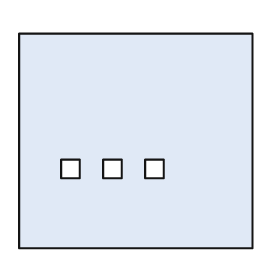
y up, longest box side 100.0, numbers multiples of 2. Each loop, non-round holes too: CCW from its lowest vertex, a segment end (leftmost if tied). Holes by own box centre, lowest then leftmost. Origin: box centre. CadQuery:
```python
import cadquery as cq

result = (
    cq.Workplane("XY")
    .moveTo(-50.0, -46.0)
    .lineTo(50.0, -46.0)
    .lineTo(50.0, 46.0)
    .lineTo(-50.0, 46.0)
    .close()
    .moveTo(-32.0, -16.0)
    .lineTo(-24.0, -16.0)
    .lineTo(-24.0, -8.0)
    .lineTo(-32.0, -8.0)
    .close()
    .moveTo(-14.0, -16.0)
    .lineTo(-6.0, -16.0)
    .lineTo(-6.0, -8.0)
    .lineTo(-14.0, -8.0)
    .close()
    .moveTo(4.0, -16.0)
    .lineTo(12.0, -16.0)
    .lineTo(12.0, -8.0)
    .lineTo(4.0, -8.0)
    .close()
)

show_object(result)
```